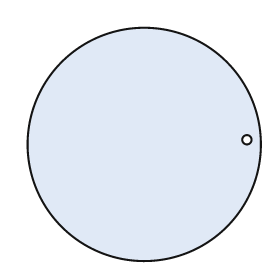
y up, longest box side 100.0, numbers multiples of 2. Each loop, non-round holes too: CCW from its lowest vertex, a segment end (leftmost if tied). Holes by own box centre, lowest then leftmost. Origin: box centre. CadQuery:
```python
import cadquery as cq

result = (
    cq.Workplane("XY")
    .moveTo(0.0, 0.0)
    .circle(50.0)
    .moveTo(44.0, 2.0)
    .circle(2.0)
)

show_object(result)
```